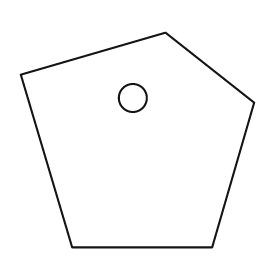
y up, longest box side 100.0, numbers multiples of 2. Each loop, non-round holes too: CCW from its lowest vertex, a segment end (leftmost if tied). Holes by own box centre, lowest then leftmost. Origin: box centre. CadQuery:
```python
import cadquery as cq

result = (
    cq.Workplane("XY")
    .moveTo(-28.0, -46.0)
    .lineTo(32.0, -46.0)
    .lineTo(50.0, 16.0)
    .lineTo(12.0, 46.0)
    .lineTo(-50.0, 28.0)
    .close()
    .moveTo(-2.0, 18.0)
    .circle(6.0)
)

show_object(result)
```